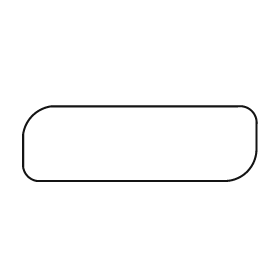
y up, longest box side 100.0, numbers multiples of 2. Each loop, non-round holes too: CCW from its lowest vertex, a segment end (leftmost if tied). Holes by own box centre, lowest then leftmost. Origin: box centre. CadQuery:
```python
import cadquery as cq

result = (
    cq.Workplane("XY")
    .moveTo(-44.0, -16.0)
    .lineTo(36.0, -16.0)
    .threePointArc((46.0, -12.0), (50.0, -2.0))
    .lineTo(50.0, 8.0)
    .threePointArc((48.0, 14.0), (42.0, 16.0))
    .lineTo(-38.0, 16.0)
    .threePointArc((-46.0, 12.0), (-50.0, 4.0))
    .lineTo(-50.0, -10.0)
    .threePointArc((-48.0, -14.0), (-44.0, -16.0))
    .close()
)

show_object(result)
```